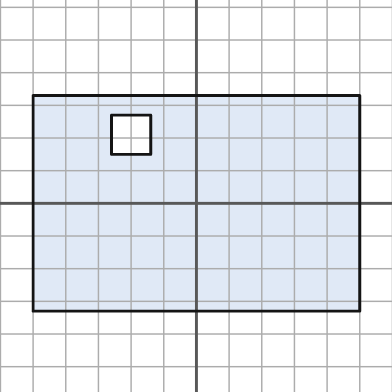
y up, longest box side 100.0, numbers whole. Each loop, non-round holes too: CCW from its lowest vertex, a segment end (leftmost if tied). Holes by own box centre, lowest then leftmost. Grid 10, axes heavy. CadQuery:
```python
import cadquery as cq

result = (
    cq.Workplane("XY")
    .moveTo(-50.0, -33.0)
    .lineTo(50.0, -33.0)
    .lineTo(50.0, 33.0)
    .lineTo(-50.0, 33.0)
    .close()
    .moveTo(-26.0, 15.0)
    .lineTo(-14.0, 15.0)
    .lineTo(-14.0, 27.0)
    .lineTo(-26.0, 27.0)
    .close()
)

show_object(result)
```